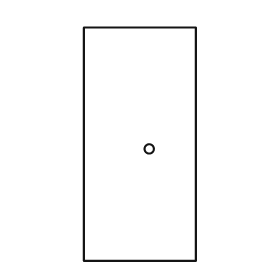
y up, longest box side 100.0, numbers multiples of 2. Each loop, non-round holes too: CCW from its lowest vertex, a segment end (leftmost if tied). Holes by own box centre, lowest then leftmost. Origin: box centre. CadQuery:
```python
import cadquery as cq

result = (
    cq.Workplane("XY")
    .moveTo(-24.0, -50.0)
    .lineTo(24.0, -50.0)
    .lineTo(24.0, 50.0)
    .lineTo(-24.0, 50.0)
    .close()
    .moveTo(4.0, -2.0)
    .circle(2.0)
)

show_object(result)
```